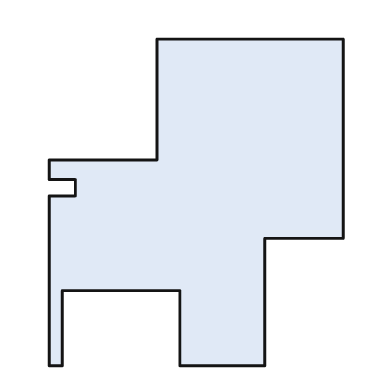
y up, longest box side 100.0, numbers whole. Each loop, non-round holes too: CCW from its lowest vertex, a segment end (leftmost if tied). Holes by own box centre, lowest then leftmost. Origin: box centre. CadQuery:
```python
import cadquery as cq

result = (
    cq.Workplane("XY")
    .moveTo(-45.0, -50.0)
    .lineTo(-41.0, -50.0)
    .lineTo(-41.0, -27.0)
    .lineTo(-5.0, -27.0)
    .lineTo(-5.0, -50.0)
    .lineTo(21.0, -50.0)
    .lineTo(21.0, -11.0)
    .lineTo(45.0, -11.0)
    .lineTo(45.0, 50.0)
    .lineTo(-12.0, 50.0)
    .lineTo(-12.0, 13.0)
    .lineTo(-45.0, 13.0)
    .lineTo(-45.0, 7.0)
    .lineTo(-37.0, 7.0)
    .lineTo(-37.0, 2.0)
    .lineTo(-45.0, 2.0)
    .close()
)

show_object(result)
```